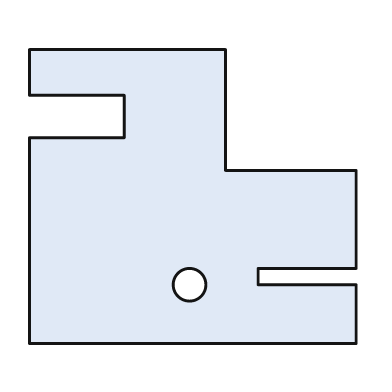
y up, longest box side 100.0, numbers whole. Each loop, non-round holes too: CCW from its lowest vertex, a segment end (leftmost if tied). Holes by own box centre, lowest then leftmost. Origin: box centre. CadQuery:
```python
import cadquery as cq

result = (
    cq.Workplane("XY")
    .moveTo(-50.0, -45.0)
    .lineTo(50.0, -45.0)
    .lineTo(50.0, -27.0)
    .lineTo(20.0, -27.0)
    .lineTo(20.0, -22.0)
    .lineTo(50.0, -22.0)
    .lineTo(50.0, 8.0)
    .lineTo(10.0, 8.0)
    .lineTo(10.0, 45.0)
    .lineTo(-50.0, 45.0)
    .lineTo(-50.0, 31.0)
    .lineTo(-21.0, 31.0)
    .lineTo(-21.0, 18.0)
    .lineTo(-50.0, 18.0)
    .close()
    .moveTo(-1.0, -27.0)
    .circle(5.0)
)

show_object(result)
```